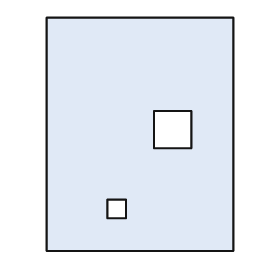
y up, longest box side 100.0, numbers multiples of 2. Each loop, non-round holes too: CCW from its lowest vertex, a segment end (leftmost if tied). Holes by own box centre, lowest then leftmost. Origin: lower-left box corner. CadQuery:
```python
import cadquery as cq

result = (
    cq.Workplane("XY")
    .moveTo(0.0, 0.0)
    .lineTo(80.0, 0.0)
    .lineTo(80.0, 100.0)
    .lineTo(0.0, 100.0)
    .close()
    .moveTo(26.0, 14.0)
    .lineTo(34.0, 14.0)
    .lineTo(34.0, 22.0)
    .lineTo(26.0, 22.0)
    .close()
    .moveTo(46.0, 44.0)
    .lineTo(62.0, 44.0)
    .lineTo(62.0, 60.0)
    .lineTo(46.0, 60.0)
    .close()
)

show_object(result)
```